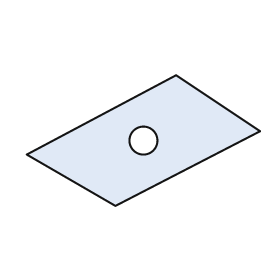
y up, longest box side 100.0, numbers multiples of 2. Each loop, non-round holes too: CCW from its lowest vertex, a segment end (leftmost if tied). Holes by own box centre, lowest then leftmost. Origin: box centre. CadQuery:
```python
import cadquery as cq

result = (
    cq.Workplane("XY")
    .moveTo(-12.0, -28.0)
    .lineTo(50.0, 4.0)
    .lineTo(14.0, 28.0)
    .lineTo(-50.0, -6.0)
    .close()
    .moveTo(0.0, 0.0)
    .circle(6.0)
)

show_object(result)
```